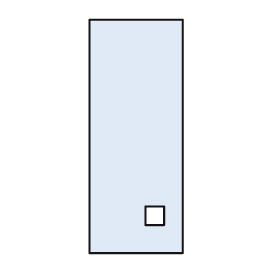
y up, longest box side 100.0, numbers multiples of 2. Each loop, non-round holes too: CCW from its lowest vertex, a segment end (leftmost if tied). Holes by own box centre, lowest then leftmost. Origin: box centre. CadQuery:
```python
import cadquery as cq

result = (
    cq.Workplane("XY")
    .moveTo(-20.0, -50.0)
    .lineTo(20.0, -50.0)
    .lineTo(20.0, 50.0)
    .lineTo(-20.0, 50.0)
    .close()
    .moveTo(4.0, -38.0)
    .lineTo(12.0, -38.0)
    .lineTo(12.0, -30.0)
    .lineTo(4.0, -30.0)
    .close()
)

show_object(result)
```